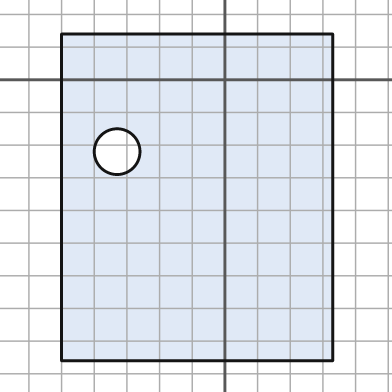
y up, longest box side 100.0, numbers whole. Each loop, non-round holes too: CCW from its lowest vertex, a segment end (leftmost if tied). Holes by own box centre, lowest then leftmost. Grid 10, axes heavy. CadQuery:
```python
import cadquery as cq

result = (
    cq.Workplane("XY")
    .moveTo(-50.0, -86.0)
    .lineTo(33.0, -86.0)
    .lineTo(33.0, 14.0)
    .lineTo(-50.0, 14.0)
    .close()
    .moveTo(-33.0, -22.0)
    .circle(7.0)
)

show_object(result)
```